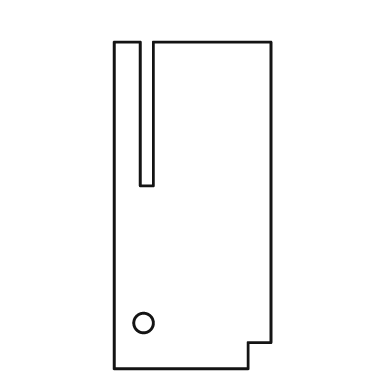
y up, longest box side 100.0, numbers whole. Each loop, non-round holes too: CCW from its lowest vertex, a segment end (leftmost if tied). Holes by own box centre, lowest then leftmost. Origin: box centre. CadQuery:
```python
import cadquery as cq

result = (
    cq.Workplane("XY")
    .moveTo(-24.0, -50.0)
    .lineTo(17.0, -50.0)
    .lineTo(17.0, -42.0)
    .lineTo(24.0, -42.0)
    .lineTo(24.0, 50.0)
    .lineTo(-12.0, 50.0)
    .lineTo(-12.0, 6.0)
    .lineTo(-16.0, 6.0)
    .lineTo(-16.0, 50.0)
    .lineTo(-24.0, 50.0)
    .close()
    .moveTo(-15.0, -36.0)
    .circle(3.0)
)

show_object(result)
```